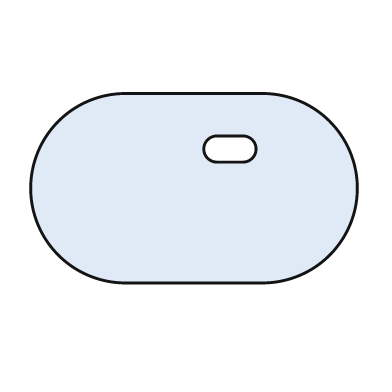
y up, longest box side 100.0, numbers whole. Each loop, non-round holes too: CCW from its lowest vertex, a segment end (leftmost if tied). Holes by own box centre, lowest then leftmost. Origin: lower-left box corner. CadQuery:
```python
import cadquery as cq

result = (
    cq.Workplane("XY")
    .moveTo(29.0, 0.0)
    .lineTo(71.0, 0.0)
    .threePointArc((100.0, 29.0), (71.0, 58.0))
    .lineTo(29.0, 58.0)
    .threePointArc((0.0, 29.0), (29.0, 0.0))
    .close()
    .moveTo(57.0, 37.0)
    .lineTo(65.0, 37.0)
    .threePointArc((69.0, 41.0), (65.0, 45.0))
    .lineTo(57.0, 45.0)
    .threePointArc((53.0, 41.0), (57.0, 37.0))
    .close()
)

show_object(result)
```